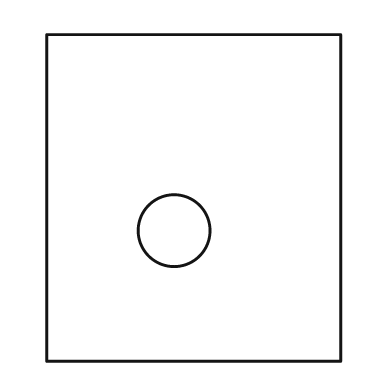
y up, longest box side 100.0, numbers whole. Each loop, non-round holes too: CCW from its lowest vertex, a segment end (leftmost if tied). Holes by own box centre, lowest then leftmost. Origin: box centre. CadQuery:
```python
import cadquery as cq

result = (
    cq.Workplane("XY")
    .moveTo(-45.0, -50.0)
    .lineTo(45.0, -50.0)
    .lineTo(45.0, 50.0)
    .lineTo(-45.0, 50.0)
    .close()
    .moveTo(-6.0, -10.0)
    .circle(11.0)
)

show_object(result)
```